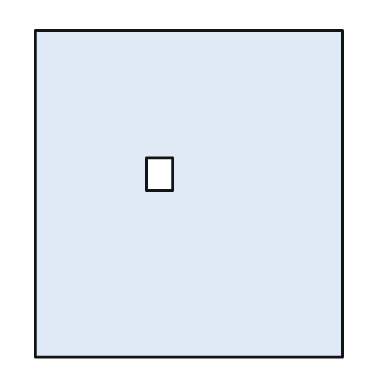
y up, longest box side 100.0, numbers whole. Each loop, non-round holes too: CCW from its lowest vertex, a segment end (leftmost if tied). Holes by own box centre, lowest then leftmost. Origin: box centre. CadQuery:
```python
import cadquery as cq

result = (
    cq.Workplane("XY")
    .moveTo(-47.0, -50.0)
    .lineTo(47.0, -50.0)
    .lineTo(47.0, 50.0)
    .lineTo(-47.0, 50.0)
    .close()
    .moveTo(-13.0, 1.0)
    .lineTo(-5.0, 1.0)
    .lineTo(-5.0, 11.0)
    .lineTo(-13.0, 11.0)
    .close()
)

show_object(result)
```